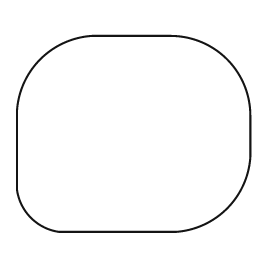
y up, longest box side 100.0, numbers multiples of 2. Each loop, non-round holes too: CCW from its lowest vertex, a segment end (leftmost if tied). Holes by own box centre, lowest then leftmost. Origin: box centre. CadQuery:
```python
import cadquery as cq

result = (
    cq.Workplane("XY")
    .moveTo(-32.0, -42.0)
    .lineTo(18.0, -42.0)
    .threePointArc((40.0, -32.0), (50.0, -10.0))
    .lineTo(50.0, 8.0)
    .threePointArc((40.0, 32.0), (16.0, 42.0))
    .lineTo(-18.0, 42.0)
    .threePointArc((-40.0, 32.0), (-50.0, 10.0))
    .lineTo(-50.0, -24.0)
    .threePointArc((-44.0, -36.0), (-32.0, -42.0))
    .close()
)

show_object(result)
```